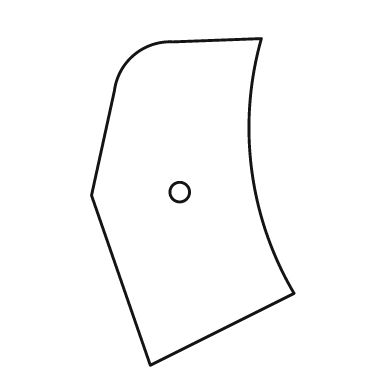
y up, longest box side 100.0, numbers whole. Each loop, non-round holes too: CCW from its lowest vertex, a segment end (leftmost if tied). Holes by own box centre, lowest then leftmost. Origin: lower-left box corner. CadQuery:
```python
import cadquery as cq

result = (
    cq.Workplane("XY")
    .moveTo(18.0, 0.0)
    .lineTo(62.0, 22.0)
    .threePointArc((49.0, 60.0), (52.0, 100.0))
    .lineTo(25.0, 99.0)
    .threePointArc((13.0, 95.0), (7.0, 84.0))
    .lineTo(0.0, 52.0)
    .close()
    .moveTo(27.0, 53.0)
    .circle(3.0)
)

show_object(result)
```